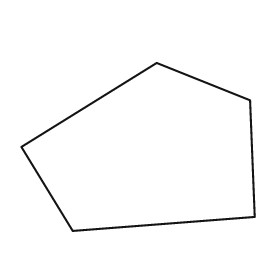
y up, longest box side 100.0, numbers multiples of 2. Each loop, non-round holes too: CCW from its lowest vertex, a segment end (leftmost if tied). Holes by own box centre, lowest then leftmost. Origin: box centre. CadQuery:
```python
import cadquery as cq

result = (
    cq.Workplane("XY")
    .moveTo(-28.0, -36.0)
    .lineTo(50.0, -30.0)
    .lineTo(48.0, 20.0)
    .lineTo(8.0, 36.0)
    .lineTo(-50.0, 0.0)
    .close()
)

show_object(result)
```